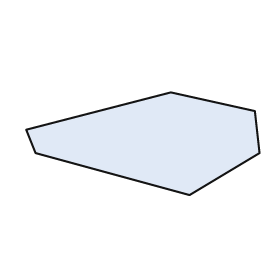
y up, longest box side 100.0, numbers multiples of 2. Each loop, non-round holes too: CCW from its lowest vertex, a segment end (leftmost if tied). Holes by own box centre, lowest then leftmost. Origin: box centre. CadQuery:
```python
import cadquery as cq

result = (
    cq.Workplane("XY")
    .moveTo(20.0, -22.0)
    .lineTo(50.0, -4.0)
    .lineTo(48.0, 14.0)
    .lineTo(12.0, 22.0)
    .lineTo(-50.0, 6.0)
    .lineTo(-46.0, -4.0)
    .close()
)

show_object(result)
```